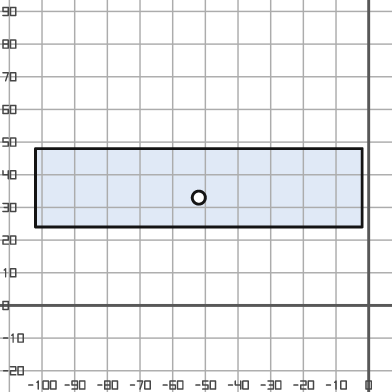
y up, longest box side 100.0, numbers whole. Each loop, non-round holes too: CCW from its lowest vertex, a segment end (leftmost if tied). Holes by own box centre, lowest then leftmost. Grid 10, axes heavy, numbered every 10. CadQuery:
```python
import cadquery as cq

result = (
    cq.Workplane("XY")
    .moveTo(-102.0, 24.0)
    .lineTo(-2.0, 24.0)
    .lineTo(-2.0, 48.0)
    .lineTo(-102.0, 48.0)
    .close()
    .moveTo(-52.0, 33.0)
    .circle(2.0)
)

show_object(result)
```